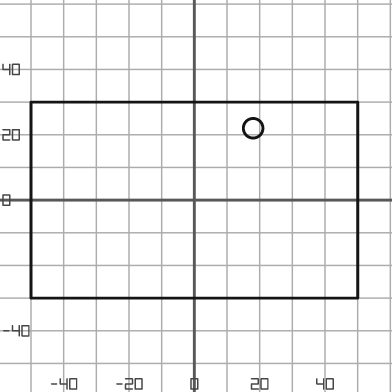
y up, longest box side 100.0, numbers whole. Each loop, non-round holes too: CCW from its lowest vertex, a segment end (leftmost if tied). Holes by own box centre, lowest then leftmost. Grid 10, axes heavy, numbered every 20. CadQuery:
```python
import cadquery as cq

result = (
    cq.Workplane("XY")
    .moveTo(-50.0, -30.0)
    .lineTo(50.0, -30.0)
    .lineTo(50.0, 30.0)
    .lineTo(-50.0, 30.0)
    .close()
    .moveTo(18.0, 22.0)
    .circle(3.0)
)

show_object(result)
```